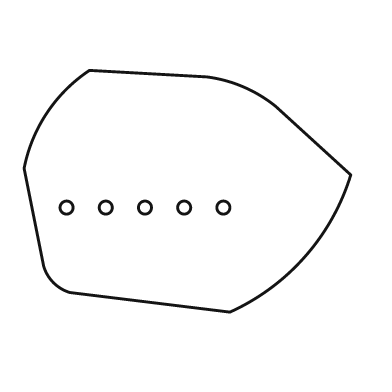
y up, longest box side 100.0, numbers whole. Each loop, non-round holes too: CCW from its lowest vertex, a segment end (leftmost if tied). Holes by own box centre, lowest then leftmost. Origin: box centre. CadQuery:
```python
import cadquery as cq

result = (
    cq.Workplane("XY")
    .moveTo(13.0, -37.0)
    .threePointArc((36.0, -20.0), (50.0, 5.0))
    .lineTo(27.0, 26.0)
    .threePointArc((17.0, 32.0), (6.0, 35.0))
    .lineTo(-30.0, 37.0)
    .threePointArc((-43.0, 24.0), (-50.0, 7.0))
    .lineTo(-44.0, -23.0)
    .threePointArc((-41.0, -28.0), (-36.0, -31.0))
    .close()
    .moveTo(-37.0, -5.0)
    .circle(2.0)
    .moveTo(-25.0, -5.0)
    .circle(2.0)
    .moveTo(-13.0, -5.0)
    .circle(2.0)
    .moveTo(-1.0, -5.0)
    .circle(2.0)
    .moveTo(11.0, -5.0)
    .circle(2.0)
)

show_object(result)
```